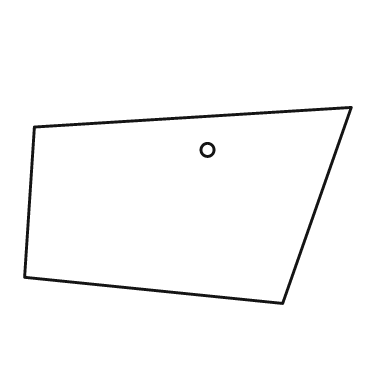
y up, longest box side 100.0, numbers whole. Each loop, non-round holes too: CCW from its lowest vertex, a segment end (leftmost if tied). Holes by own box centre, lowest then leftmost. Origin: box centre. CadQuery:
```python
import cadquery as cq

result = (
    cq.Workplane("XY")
    .moveTo(29.0, -30.0)
    .lineTo(50.0, 30.0)
    .lineTo(-47.0, 24.0)
    .lineTo(-50.0, -22.0)
    .close()
    .moveTo(6.0, 17.0)
    .circle(2.0)
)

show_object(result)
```